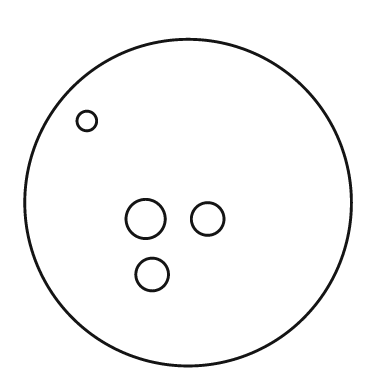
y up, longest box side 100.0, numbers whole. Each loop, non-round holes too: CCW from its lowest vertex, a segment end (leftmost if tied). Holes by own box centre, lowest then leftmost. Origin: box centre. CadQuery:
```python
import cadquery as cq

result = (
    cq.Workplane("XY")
    .moveTo(0.0, 0.0)
    .circle(50.0)
    .moveTo(-11.0, -22.0)
    .circle(5.0)
    .moveTo(-13.0, -5.0)
    .circle(6.0)
    .moveTo(6.0, -5.0)
    .circle(5.0)
    .moveTo(-31.0, 25.0)
    .circle(3.0)
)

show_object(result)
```